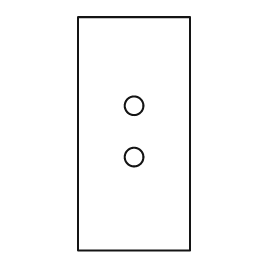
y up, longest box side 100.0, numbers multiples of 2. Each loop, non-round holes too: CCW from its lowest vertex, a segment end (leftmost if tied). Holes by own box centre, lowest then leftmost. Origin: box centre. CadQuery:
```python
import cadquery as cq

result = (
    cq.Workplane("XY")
    .moveTo(-24.0, -50.0)
    .lineTo(24.0, -50.0)
    .lineTo(24.0, 50.0)
    .lineTo(-24.0, 50.0)
    .close()
    .moveTo(0.0, -10.0)
    .circle(4.0)
    .moveTo(0.0, 12.0)
    .circle(4.0)
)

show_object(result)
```